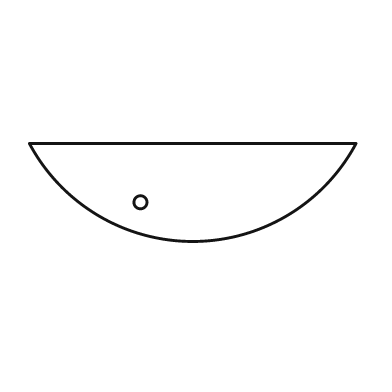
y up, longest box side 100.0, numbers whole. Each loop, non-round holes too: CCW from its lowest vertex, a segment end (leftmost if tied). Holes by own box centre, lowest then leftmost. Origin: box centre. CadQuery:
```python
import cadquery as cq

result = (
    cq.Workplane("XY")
    .moveTo(-50.0, 15.0)
    .threePointArc((0.0, -15.0), (50.0, 15.0))
    .close()
    .moveTo(-16.0, -3.0)
    .circle(2.0)
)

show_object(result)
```